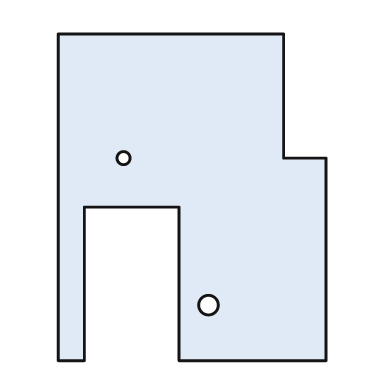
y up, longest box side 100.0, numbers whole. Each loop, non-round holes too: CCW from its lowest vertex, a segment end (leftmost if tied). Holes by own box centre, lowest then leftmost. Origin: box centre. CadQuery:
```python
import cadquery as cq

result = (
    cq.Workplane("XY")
    .moveTo(-41.0, -50.0)
    .lineTo(-33.0, -50.0)
    .lineTo(-33.0, -3.0)
    .lineTo(-4.0, -3.0)
    .lineTo(-4.0, -50.0)
    .lineTo(41.0, -50.0)
    .lineTo(41.0, 12.0)
    .lineTo(28.0, 12.0)
    .lineTo(28.0, 50.0)
    .lineTo(-41.0, 50.0)
    .close()
    .moveTo(5.0, -33.0)
    .circle(3.0)
    .moveTo(-21.0, 12.0)
    .circle(2.0)
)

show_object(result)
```